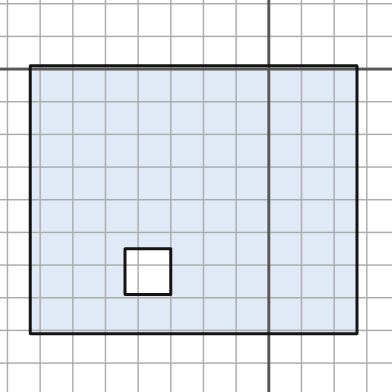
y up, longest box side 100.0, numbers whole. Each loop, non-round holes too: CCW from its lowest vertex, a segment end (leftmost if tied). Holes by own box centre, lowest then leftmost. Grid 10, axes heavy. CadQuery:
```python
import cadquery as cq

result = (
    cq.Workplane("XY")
    .moveTo(-73.0, -81.0)
    .lineTo(27.0, -81.0)
    .lineTo(27.0, 1.0)
    .lineTo(-73.0, 1.0)
    .close()
    .moveTo(-44.0, -69.0)
    .lineTo(-30.0, -69.0)
    .lineTo(-30.0, -55.0)
    .lineTo(-44.0, -55.0)
    .close()
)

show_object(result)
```